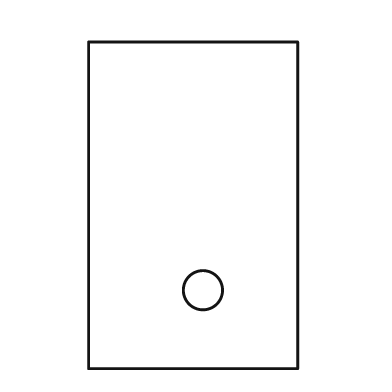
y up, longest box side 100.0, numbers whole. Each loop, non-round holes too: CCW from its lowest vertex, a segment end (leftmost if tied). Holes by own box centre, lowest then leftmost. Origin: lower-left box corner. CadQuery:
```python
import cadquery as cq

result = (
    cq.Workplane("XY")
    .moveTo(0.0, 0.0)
    .lineTo(64.0, 0.0)
    .lineTo(64.0, 100.0)
    .lineTo(0.0, 100.0)
    .close()
    .moveTo(35.0, 24.0)
    .circle(6.0)
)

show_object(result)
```